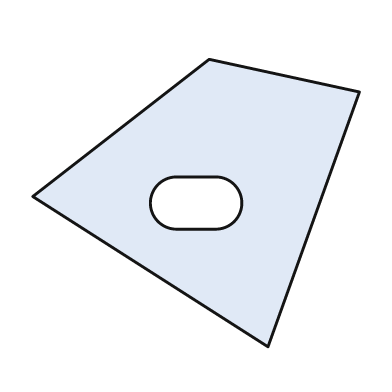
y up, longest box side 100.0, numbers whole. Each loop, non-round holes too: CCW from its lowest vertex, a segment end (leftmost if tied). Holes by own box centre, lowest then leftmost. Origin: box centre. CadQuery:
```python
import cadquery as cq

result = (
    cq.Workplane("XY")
    .moveTo(22.0, -44.0)
    .lineTo(50.0, 34.0)
    .lineTo(4.0, 44.0)
    .lineTo(-50.0, 2.0)
    .close()
    .moveTo(-6.0, -8.0)
    .lineTo(6.0, -8.0)
    .threePointArc((14.0, 0.0), (6.0, 8.0))
    .lineTo(-6.0, 8.0)
    .threePointArc((-14.0, 0.0), (-6.0, -8.0))
    .close()
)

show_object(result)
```